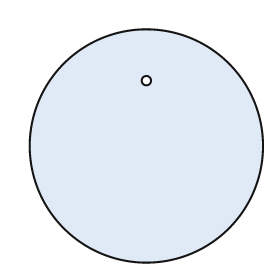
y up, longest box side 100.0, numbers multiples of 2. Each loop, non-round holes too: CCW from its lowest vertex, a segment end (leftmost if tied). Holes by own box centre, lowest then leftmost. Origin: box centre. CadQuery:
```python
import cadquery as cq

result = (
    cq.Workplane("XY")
    .moveTo(0.0, 0.0)
    .circle(50.0)
    .moveTo(0.0, 28.0)
    .circle(2.0)
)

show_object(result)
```